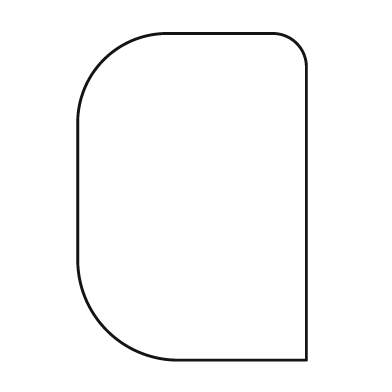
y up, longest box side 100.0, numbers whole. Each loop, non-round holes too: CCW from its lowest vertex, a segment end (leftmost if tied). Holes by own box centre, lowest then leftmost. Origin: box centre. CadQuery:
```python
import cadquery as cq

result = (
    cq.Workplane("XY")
    .moveTo(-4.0, -50.0)
    .lineTo(35.0, -50.0)
    .lineTo(35.0, 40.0)
    .threePointArc((32.0, 47.0), (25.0, 50.0))
    .lineTo(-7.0, 50.0)
    .threePointArc((-27.0, 42.0), (-35.0, 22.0))
    .lineTo(-35.0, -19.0)
    .threePointArc((-26.0, -41.0), (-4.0, -50.0))
    .close()
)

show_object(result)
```